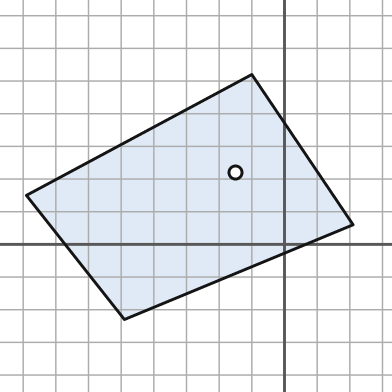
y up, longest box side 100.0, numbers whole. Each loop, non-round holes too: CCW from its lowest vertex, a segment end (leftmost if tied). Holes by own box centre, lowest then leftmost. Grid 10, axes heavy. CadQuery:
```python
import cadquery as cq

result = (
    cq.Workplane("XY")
    .moveTo(-49.0, -23.0)
    .lineTo(21.0, 6.0)
    .lineTo(-10.0, 52.0)
    .lineTo(-79.0, 15.0)
    .close()
    .moveTo(-15.0, 22.0)
    .circle(2.0)
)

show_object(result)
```